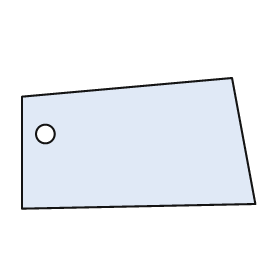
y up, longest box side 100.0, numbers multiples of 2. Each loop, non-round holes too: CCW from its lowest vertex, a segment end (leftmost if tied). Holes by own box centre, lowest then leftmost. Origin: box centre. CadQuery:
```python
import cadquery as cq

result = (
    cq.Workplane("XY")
    .moveTo(-50.0, -28.0)
    .lineTo(50.0, -26.0)
    .lineTo(40.0, 28.0)
    .lineTo(-50.0, 20.0)
    .close()
    .moveTo(-40.0, 4.0)
    .circle(4.0)
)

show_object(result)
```